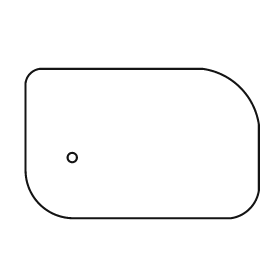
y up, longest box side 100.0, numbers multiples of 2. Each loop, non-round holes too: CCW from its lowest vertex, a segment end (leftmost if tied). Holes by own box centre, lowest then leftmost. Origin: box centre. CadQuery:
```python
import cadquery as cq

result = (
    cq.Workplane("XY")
    .moveTo(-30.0, -32.0)
    .lineTo(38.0, -32.0)
    .threePointArc((46.0, -28.0), (50.0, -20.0))
    .lineTo(50.0, 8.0)
    .threePointArc((42.0, 24.0), (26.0, 32.0))
    .lineTo(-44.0, 32.0)
    .threePointArc((-48.0, 30.0), (-50.0, 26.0))
    .lineTo(-50.0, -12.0)
    .threePointArc((-44.0, -26.0), (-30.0, -32.0))
    .close()
    .moveTo(-30.0, -6.0)
    .circle(2.0)
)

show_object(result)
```